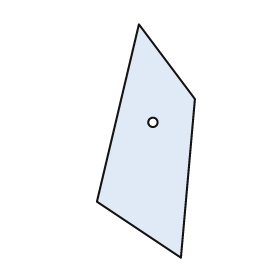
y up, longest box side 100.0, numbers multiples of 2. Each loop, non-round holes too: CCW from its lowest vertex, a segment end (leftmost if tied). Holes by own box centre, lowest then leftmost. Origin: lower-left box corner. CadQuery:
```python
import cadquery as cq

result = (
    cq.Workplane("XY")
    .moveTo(36.0, 0.0)
    .lineTo(42.0, 68.0)
    .lineTo(18.0, 100.0)
    .lineTo(0.0, 24.0)
    .close()
    .moveTo(24.0, 58.0)
    .circle(2.0)
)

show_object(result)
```